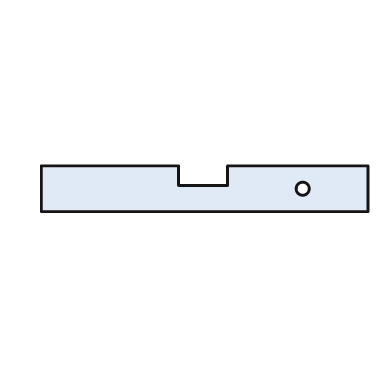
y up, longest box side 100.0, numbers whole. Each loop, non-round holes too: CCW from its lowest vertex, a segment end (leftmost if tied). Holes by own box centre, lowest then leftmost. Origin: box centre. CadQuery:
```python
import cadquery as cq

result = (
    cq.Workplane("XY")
    .moveTo(-50.0, -7.0)
    .lineTo(50.0, -7.0)
    .lineTo(50.0, 7.0)
    .lineTo(7.0, 7.0)
    .lineTo(7.0, 1.0)
    .lineTo(-8.0, 1.0)
    .lineTo(-8.0, 7.0)
    .lineTo(-50.0, 7.0)
    .close()
    .moveTo(30.0, 0.0)
    .circle(2.0)
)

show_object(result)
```